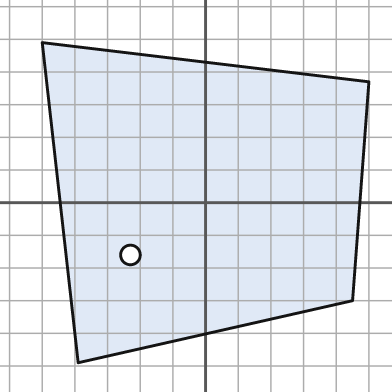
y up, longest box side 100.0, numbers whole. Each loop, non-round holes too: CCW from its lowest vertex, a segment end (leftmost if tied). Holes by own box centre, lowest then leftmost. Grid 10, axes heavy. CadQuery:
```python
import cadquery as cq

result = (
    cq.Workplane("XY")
    .moveTo(-39.0, -49.0)
    .lineTo(45.0, -30.0)
    .lineTo(50.0, 37.0)
    .lineTo(-50.0, 49.0)
    .close()
    .moveTo(-23.0, -16.0)
    .circle(3.0)
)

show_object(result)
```